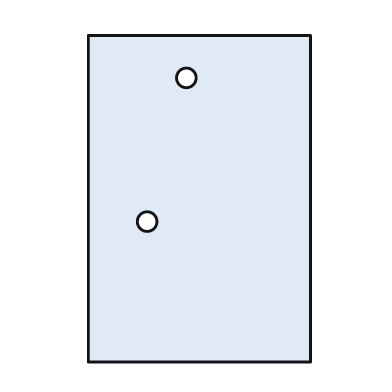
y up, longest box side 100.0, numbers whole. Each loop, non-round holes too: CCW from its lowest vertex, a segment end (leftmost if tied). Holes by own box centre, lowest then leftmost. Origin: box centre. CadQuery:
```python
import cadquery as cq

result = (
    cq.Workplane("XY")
    .moveTo(-34.0, -50.0)
    .lineTo(34.0, -50.0)
    .lineTo(34.0, 50.0)
    .lineTo(-34.0, 50.0)
    .close()
    .moveTo(-16.0, -7.0)
    .circle(3.0)
    .moveTo(-4.0, 37.0)
    .circle(3.0)
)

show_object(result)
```